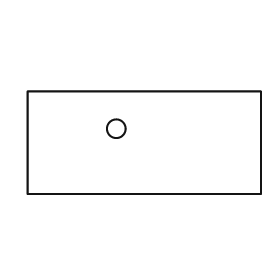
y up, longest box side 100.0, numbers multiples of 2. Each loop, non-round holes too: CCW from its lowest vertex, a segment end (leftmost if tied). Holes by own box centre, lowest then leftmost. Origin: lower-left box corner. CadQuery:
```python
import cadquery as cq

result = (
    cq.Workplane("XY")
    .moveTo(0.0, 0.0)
    .lineTo(100.0, 0.0)
    .lineTo(100.0, 44.0)
    .lineTo(0.0, 44.0)
    .close()
    .moveTo(38.0, 28.0)
    .circle(4.0)
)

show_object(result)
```